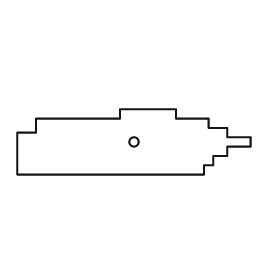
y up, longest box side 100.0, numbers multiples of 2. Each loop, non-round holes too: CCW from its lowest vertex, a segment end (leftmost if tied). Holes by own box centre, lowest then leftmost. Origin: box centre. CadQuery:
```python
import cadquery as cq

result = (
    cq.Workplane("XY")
    .moveTo(-50.0, -14.0)
    .lineTo(30.0, -14.0)
    .lineTo(30.0, -10.0)
    .lineTo(34.0, -10.0)
    .lineTo(34.0, -6.0)
    .lineTo(40.0, -6.0)
    .lineTo(40.0, -2.0)
    .lineTo(50.0, -2.0)
    .lineTo(50.0, 2.0)
    .lineTo(40.0, 2.0)
    .lineTo(40.0, 6.0)
    .lineTo(32.0, 6.0)
    .lineTo(32.0, 10.0)
    .lineTo(18.0, 10.0)
    .lineTo(18.0, 14.0)
    .lineTo(-6.0, 14.0)
    .lineTo(-6.0, 10.0)
    .lineTo(-42.0, 10.0)
    .lineTo(-42.0, 4.0)
    .lineTo(-50.0, 4.0)
    .close()
    .moveTo(0.0, 0.0)
    .circle(2.0)
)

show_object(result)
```